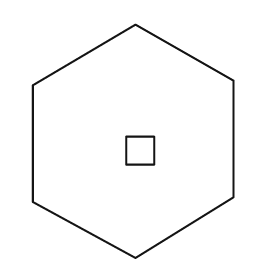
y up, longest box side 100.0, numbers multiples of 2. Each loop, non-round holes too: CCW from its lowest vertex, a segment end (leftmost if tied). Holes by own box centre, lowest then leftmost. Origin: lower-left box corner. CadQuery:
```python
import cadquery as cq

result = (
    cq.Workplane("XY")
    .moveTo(44.0, 0.0)
    .lineTo(86.0, 26.0)
    .lineTo(86.0, 76.0)
    .lineTo(44.0, 100.0)
    .lineTo(0.0, 74.0)
    .lineTo(0.0, 24.0)
    .close()
    .moveTo(40.0, 40.0)
    .lineTo(52.0, 40.0)
    .lineTo(52.0, 52.0)
    .lineTo(40.0, 52.0)
    .close()
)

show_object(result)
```